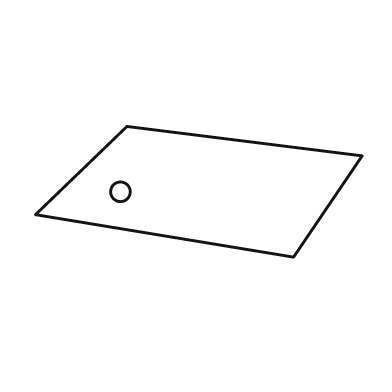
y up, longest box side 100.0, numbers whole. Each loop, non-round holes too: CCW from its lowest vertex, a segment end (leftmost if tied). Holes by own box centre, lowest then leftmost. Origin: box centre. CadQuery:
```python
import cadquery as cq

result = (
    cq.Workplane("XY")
    .moveTo(29.0, -20.0)
    .lineTo(50.0, 11.0)
    .lineTo(-22.0, 20.0)
    .lineTo(-50.0, -7.0)
    .close()
    .moveTo(-24.0, 0.0)
    .circle(3.0)
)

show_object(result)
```